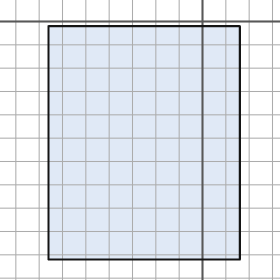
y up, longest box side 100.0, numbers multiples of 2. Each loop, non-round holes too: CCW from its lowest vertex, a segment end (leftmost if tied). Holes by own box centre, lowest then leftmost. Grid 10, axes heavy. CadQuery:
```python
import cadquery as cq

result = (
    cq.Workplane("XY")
    .moveTo(-66.0, -102.0)
    .lineTo(16.0, -102.0)
    .lineTo(16.0, -2.0)
    .lineTo(-66.0, -2.0)
    .close()
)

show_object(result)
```